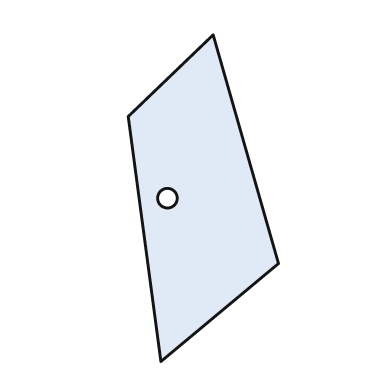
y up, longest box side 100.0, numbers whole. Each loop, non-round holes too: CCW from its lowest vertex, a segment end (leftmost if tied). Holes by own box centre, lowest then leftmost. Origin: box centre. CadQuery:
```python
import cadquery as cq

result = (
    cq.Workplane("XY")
    .moveTo(-13.0, -50.0)
    .lineTo(23.0, -20.0)
    .lineTo(3.0, 50.0)
    .lineTo(-23.0, 25.0)
    .close()
    .moveTo(-11.0, 0.0)
    .circle(3.0)
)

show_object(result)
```